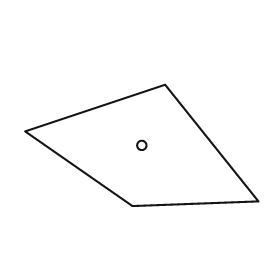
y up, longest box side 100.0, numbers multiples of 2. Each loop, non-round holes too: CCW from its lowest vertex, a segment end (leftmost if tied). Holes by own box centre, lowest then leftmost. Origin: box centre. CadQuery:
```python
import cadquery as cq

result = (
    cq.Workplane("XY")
    .moveTo(-4.0, -26.0)
    .lineTo(50.0, -24.0)
    .lineTo(10.0, 26.0)
    .lineTo(-50.0, 6.0)
    .close()
    .moveTo(0.0, 0.0)
    .circle(2.0)
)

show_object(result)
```